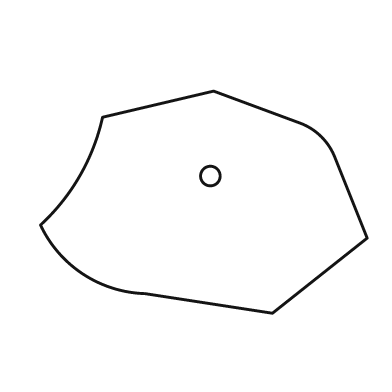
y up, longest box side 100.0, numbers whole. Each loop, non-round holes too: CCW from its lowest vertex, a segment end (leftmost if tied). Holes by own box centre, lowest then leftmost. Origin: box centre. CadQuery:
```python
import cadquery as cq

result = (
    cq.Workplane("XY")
    .moveTo(21.0, -34.0)
    .lineTo(50.0, -11.0)
    .lineTo(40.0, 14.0)
    .threePointArc((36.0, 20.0), (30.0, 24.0))
    .lineTo(3.0, 34.0)
    .lineTo(-31.0, 26.0)
    .threePointArc((-38.0, 8.0), (-50.0, -7.0))
    .threePointArc((-37.0, -22.0), (-18.0, -28.0))
    .close()
    .moveTo(2.0, 8.0)
    .circle(3.0)
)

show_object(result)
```